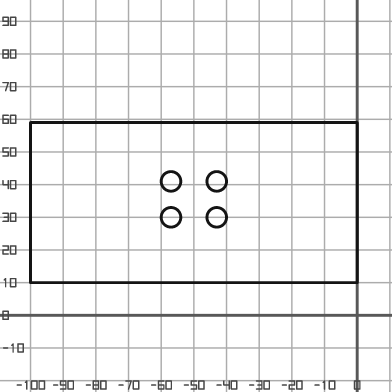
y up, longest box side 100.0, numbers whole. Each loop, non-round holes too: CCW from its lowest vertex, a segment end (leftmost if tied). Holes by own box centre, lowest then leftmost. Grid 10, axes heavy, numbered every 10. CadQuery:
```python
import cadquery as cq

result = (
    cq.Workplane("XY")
    .moveTo(-100.0, 10.0)
    .lineTo(0.0, 10.0)
    .lineTo(0.0, 59.0)
    .lineTo(-100.0, 59.0)
    .close()
    .moveTo(-57.0, 30.0)
    .circle(3.0)
    .moveTo(-43.0, 30.0)
    .circle(3.0)
    .moveTo(-57.0, 41.0)
    .circle(3.0)
    .moveTo(-43.0, 41.0)
    .circle(3.0)
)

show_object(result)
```